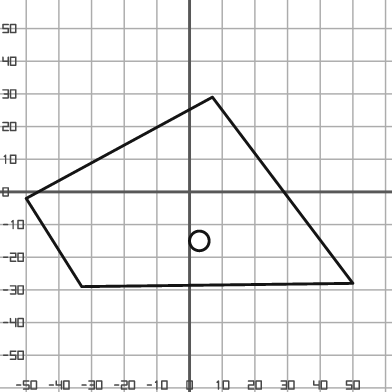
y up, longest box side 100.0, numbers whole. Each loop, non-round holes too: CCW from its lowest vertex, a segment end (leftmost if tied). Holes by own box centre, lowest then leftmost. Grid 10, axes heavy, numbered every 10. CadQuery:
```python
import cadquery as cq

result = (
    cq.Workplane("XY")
    .moveTo(-33.0, -29.0)
    .lineTo(50.0, -28.0)
    .lineTo(7.0, 29.0)
    .lineTo(-50.0, -2.0)
    .close()
    .moveTo(3.0, -15.0)
    .circle(3.0)
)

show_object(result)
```